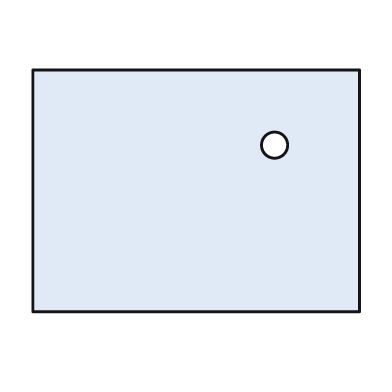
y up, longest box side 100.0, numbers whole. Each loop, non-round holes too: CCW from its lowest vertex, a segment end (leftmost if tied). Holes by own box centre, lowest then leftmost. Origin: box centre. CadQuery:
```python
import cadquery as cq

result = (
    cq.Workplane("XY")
    .moveTo(-50.0, -37.0)
    .lineTo(50.0, -37.0)
    .lineTo(50.0, 37.0)
    .lineTo(-50.0, 37.0)
    .close()
    .moveTo(24.0, 14.0)
    .circle(4.0)
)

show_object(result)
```